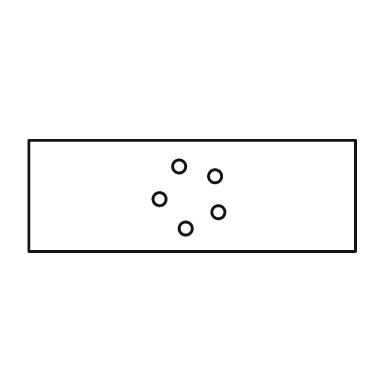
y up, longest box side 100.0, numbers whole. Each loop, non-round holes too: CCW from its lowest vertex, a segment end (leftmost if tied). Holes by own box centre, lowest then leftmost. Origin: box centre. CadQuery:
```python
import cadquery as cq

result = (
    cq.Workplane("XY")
    .moveTo(-50.0, -17.0)
    .lineTo(50.0, -17.0)
    .lineTo(50.0, 17.0)
    .lineTo(-50.0, 17.0)
    .close()
    .moveTo(-2.0, -10.0)
    .circle(2.0)
    .moveTo(8.0, -5.0)
    .circle(2.0)
    .moveTo(-10.0, -1.0)
    .circle(2.0)
    .moveTo(7.0, 6.0)
    .circle(2.0)
    .moveTo(-4.0, 9.0)
    .circle(2.0)
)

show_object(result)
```